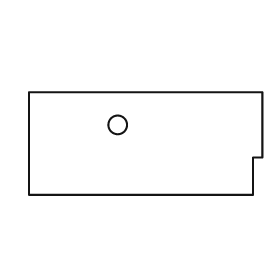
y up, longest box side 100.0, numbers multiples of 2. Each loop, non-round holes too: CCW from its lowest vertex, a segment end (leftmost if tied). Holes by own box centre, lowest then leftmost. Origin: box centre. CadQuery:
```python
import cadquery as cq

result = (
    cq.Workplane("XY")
    .moveTo(-50.0, -22.0)
    .lineTo(46.0, -22.0)
    .lineTo(46.0, -6.0)
    .lineTo(50.0, -6.0)
    .lineTo(50.0, 22.0)
    .lineTo(-50.0, 22.0)
    .close()
    .moveTo(-12.0, 8.0)
    .circle(4.0)
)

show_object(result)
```